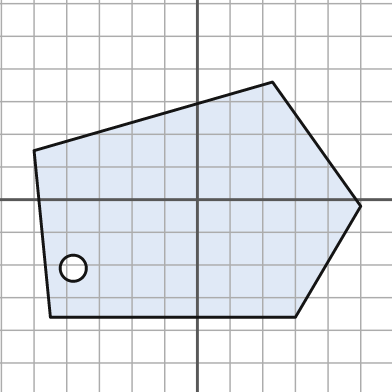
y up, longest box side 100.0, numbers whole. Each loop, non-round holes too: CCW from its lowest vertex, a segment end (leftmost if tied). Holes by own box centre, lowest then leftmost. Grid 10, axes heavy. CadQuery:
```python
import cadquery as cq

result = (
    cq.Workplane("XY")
    .moveTo(-45.0, -36.0)
    .lineTo(30.0, -36.0)
    .lineTo(50.0, -2.0)
    .lineTo(23.0, 36.0)
    .lineTo(-50.0, 15.0)
    .close()
    .moveTo(-38.0, -21.0)
    .circle(4.0)
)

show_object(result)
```